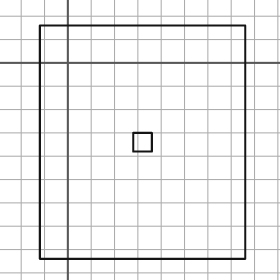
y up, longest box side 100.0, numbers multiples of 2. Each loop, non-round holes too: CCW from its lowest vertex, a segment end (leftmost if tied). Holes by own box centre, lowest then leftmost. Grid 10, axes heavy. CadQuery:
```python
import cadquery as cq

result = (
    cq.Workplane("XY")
    .moveTo(-12.0, -84.0)
    .lineTo(76.0, -84.0)
    .lineTo(76.0, 16.0)
    .lineTo(-12.0, 16.0)
    .close()
    .moveTo(28.0, -38.0)
    .lineTo(36.0, -38.0)
    .lineTo(36.0, -30.0)
    .lineTo(28.0, -30.0)
    .close()
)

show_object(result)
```